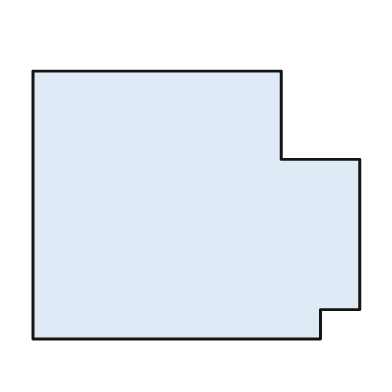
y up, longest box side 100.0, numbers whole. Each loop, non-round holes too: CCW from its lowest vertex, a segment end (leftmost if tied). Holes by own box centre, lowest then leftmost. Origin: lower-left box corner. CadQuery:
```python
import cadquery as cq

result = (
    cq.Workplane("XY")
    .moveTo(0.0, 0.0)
    .lineTo(88.0, 0.0)
    .lineTo(88.0, 9.0)
    .lineTo(100.0, 9.0)
    .lineTo(100.0, 55.0)
    .lineTo(76.0, 55.0)
    .lineTo(76.0, 82.0)
    .lineTo(0.0, 82.0)
    .close()
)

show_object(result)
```